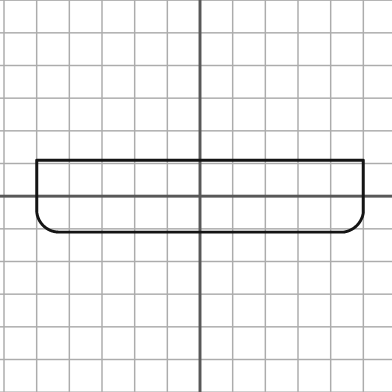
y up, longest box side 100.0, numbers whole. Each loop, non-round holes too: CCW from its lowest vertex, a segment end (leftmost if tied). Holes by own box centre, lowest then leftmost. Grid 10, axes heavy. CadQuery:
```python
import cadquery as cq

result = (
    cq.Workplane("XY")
    .moveTo(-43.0, -11.0)
    .lineTo(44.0, -11.0)
    .threePointArc((48.0, -9.0), (50.0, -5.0))
    .lineTo(50.0, 11.0)
    .lineTo(-50.0, 11.0)
    .lineTo(-50.0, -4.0)
    .threePointArc((-48.0, -9.0), (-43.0, -11.0))
    .close()
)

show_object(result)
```